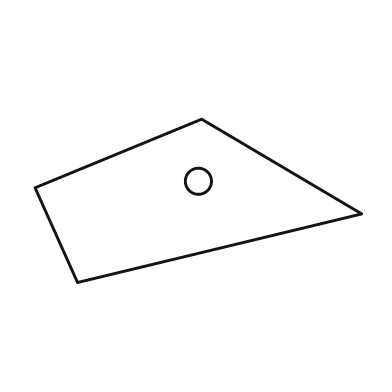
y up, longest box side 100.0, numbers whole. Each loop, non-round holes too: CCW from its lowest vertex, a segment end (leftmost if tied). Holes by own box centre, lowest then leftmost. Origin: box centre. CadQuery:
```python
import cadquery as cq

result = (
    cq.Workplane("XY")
    .moveTo(-37.0, -25.0)
    .lineTo(50.0, -4.0)
    .lineTo(1.0, 25.0)
    .lineTo(-50.0, 4.0)
    .close()
    .moveTo(0.0, 6.0)
    .circle(4.0)
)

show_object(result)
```